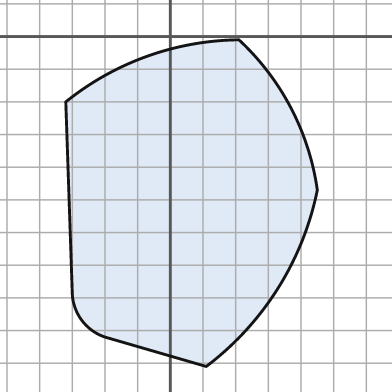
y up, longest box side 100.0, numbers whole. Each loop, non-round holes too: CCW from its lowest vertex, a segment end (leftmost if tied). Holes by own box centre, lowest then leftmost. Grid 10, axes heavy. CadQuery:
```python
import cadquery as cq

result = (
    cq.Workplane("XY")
    .moveTo(11.0, -101.0)
    .threePointArc((33.0, -77.0), (45.0, -47.0))
    .threePointArc((37.0, -22.0), (21.0, -1.0))
    .threePointArc((-7.0, -6.0), (-32.0, -20.0))
    .lineTo(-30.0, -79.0)
    .threePointArc((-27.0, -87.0), (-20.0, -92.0))
    .close()
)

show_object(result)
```